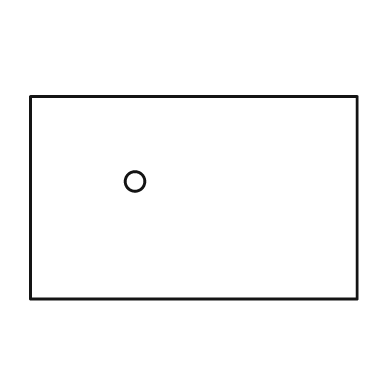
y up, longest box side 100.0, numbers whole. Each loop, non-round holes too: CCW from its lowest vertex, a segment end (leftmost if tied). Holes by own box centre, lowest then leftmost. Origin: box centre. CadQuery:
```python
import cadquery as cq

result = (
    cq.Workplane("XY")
    .moveTo(-50.0, -31.0)
    .lineTo(50.0, -31.0)
    .lineTo(50.0, 31.0)
    .lineTo(-50.0, 31.0)
    .close()
    .moveTo(-18.0, 5.0)
    .circle(3.0)
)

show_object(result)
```